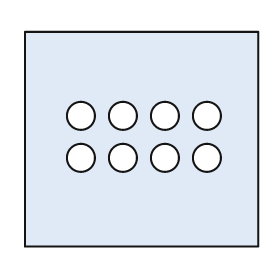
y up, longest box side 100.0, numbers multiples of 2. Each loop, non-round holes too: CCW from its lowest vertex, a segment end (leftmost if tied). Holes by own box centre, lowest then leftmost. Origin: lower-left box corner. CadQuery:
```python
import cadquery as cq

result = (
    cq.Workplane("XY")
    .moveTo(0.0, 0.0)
    .lineTo(100.0, 0.0)
    .lineTo(100.0, 92.0)
    .lineTo(0.0, 92.0)
    .close()
    .moveTo(24.0, 38.0)
    .circle(6.0)
    .moveTo(42.0, 38.0)
    .circle(6.0)
    .moveTo(60.0, 38.0)
    .circle(6.0)
    .moveTo(78.0, 38.0)
    .circle(6.0)
    .moveTo(24.0, 56.0)
    .circle(6.0)
    .moveTo(42.0, 56.0)
    .circle(6.0)
    .moveTo(60.0, 56.0)
    .circle(6.0)
    .moveTo(78.0, 56.0)
    .circle(6.0)
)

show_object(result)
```